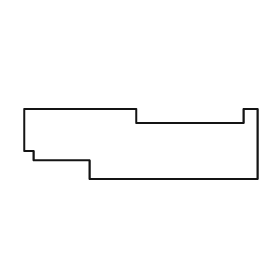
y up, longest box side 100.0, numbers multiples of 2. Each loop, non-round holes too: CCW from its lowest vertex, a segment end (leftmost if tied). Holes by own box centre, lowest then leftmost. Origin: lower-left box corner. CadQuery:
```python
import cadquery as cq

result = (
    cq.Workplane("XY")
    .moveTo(28.0, 0.0)
    .lineTo(100.0, 0.0)
    .lineTo(100.0, 30.0)
    .lineTo(94.0, 30.0)
    .lineTo(94.0, 24.0)
    .lineTo(48.0, 24.0)
    .lineTo(48.0, 30.0)
    .lineTo(0.0, 30.0)
    .lineTo(0.0, 12.0)
    .lineTo(4.0, 12.0)
    .lineTo(4.0, 8.0)
    .lineTo(28.0, 8.0)
    .close()
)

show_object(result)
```